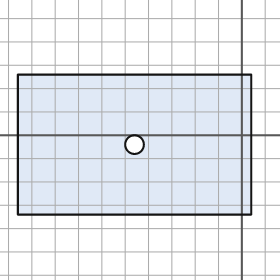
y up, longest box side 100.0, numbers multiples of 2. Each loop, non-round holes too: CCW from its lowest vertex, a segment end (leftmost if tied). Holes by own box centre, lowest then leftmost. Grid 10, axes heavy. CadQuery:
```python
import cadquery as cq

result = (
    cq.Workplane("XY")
    .moveTo(-96.0, -34.0)
    .lineTo(4.0, -34.0)
    .lineTo(4.0, 26.0)
    .lineTo(-96.0, 26.0)
    .close()
    .moveTo(-46.0, -4.0)
    .circle(4.0)
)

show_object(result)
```